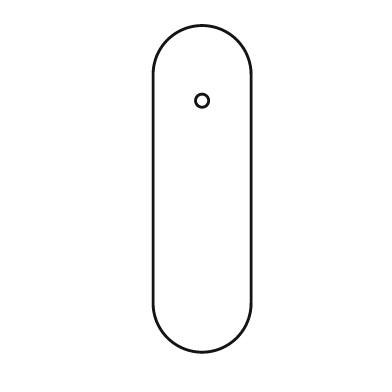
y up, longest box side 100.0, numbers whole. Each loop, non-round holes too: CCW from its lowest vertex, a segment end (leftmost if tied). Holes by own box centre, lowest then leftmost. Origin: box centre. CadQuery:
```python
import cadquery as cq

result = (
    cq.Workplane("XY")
    .moveTo(-15.0, -35.0)
    .threePointArc((0.0, -50.0), (15.0, -35.0))
    .lineTo(15.0, 35.0)
    .threePointArc((0.0, 50.0), (-15.0, 35.0))
    .close()
    .moveTo(0.0, 27.0)
    .circle(2.0)
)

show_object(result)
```